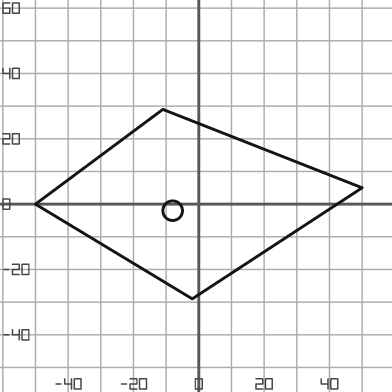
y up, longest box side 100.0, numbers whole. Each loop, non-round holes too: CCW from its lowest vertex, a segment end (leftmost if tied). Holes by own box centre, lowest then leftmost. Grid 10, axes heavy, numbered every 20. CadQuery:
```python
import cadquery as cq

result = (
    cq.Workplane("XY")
    .moveTo(-2.0, -29.0)
    .lineTo(50.0, 5.0)
    .lineTo(-11.0, 29.0)
    .lineTo(-50.0, 0.0)
    .close()
    .moveTo(-8.0, -2.0)
    .circle(3.0)
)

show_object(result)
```